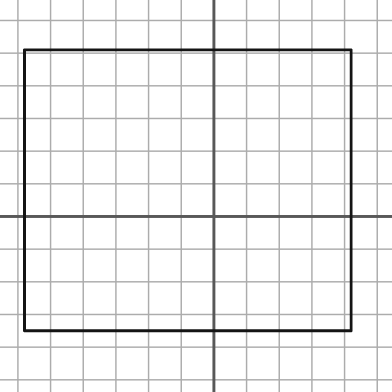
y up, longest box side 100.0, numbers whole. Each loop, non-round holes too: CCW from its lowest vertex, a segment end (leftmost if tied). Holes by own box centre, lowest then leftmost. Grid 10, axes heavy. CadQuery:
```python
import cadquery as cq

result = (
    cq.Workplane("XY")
    .moveTo(-58.0, -35.0)
    .lineTo(42.0, -35.0)
    .lineTo(42.0, 51.0)
    .lineTo(-58.0, 51.0)
    .close()
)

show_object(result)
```